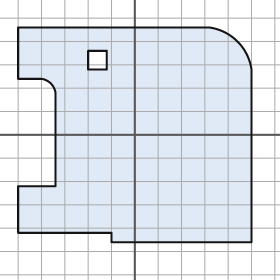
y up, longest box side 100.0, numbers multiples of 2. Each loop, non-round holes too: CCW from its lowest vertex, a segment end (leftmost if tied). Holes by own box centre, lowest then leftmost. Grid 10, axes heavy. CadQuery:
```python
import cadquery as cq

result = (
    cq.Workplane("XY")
    .moveTo(-10.0, -46.0)
    .lineTo(50.0, -46.0)
    .lineTo(50.0, 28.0)
    .threePointArc((44.0, 40.0), (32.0, 46.0))
    .lineTo(-50.0, 46.0)
    .lineTo(-50.0, 24.0)
    .lineTo(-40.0, 24.0)
    .threePointArc((-36.0, 22.0), (-34.0, 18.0))
    .lineTo(-34.0, -22.0)
    .lineTo(-50.0, -22.0)
    .lineTo(-50.0, -42.0)
    .lineTo(-10.0, -42.0)
    .close()
    .moveTo(-20.0, 28.0)
    .lineTo(-12.0, 28.0)
    .lineTo(-12.0, 36.0)
    .lineTo(-20.0, 36.0)
    .close()
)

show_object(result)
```